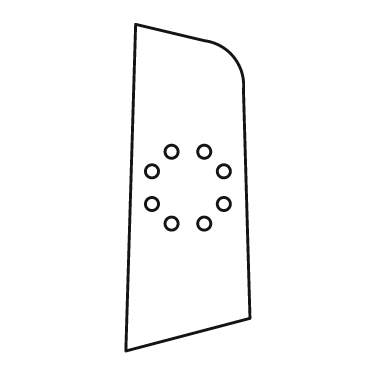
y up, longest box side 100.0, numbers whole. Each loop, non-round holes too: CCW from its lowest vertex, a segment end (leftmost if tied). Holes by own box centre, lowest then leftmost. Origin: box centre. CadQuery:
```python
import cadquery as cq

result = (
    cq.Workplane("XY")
    .moveTo(-19.0, -50.0)
    .lineTo(19.0, -40.0)
    .lineTo(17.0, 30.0)
    .threePointArc((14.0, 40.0), (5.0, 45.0))
    .lineTo(-16.0, 50.0)
    .close()
    .moveTo(-5.0, -11.0)
    .circle(2.0)
    .moveTo(5.0, -11.0)
    .circle(2.0)
    .moveTo(-11.0, -5.0)
    .circle(2.0)
    .moveTo(11.0, -5.0)
    .circle(2.0)
    .moveTo(-11.0, 5.0)
    .circle(2.0)
    .moveTo(11.0, 5.0)
    .circle(2.0)
    .moveTo(-5.0, 11.0)
    .circle(2.0)
    .moveTo(5.0, 11.0)
    .circle(2.0)
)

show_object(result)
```